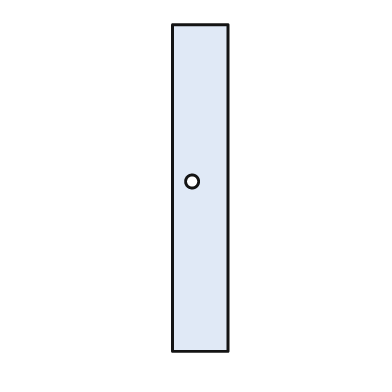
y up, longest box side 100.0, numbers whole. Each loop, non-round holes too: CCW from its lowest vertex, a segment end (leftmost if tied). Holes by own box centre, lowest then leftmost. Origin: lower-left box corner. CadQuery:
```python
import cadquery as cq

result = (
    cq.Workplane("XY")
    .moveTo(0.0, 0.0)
    .lineTo(17.0, 0.0)
    .lineTo(17.0, 100.0)
    .lineTo(0.0, 100.0)
    .close()
    .moveTo(6.0, 52.0)
    .circle(2.0)
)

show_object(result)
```